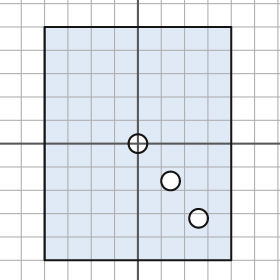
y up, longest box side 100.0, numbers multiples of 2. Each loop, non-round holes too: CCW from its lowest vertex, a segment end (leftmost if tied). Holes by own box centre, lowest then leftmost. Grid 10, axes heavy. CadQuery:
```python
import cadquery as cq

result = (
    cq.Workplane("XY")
    .moveTo(-40.0, -50.0)
    .lineTo(40.0, -50.0)
    .lineTo(40.0, 50.0)
    .lineTo(-40.0, 50.0)
    .close()
    .moveTo(26.0, -32.0)
    .circle(4.0)
    .moveTo(14.0, -16.0)
    .circle(4.0)
    .moveTo(0.0, 0.0)
    .circle(4.0)
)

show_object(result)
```